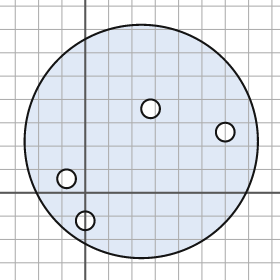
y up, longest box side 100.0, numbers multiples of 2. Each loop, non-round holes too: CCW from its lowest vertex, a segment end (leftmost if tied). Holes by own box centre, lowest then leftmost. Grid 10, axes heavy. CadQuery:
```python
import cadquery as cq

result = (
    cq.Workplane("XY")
    .moveTo(24.0, 22.0)
    .circle(50.0)
    .moveTo(0.0, -12.0)
    .circle(4.0)
    .moveTo(-8.0, 6.0)
    .circle(4.0)
    .moveTo(60.0, 26.0)
    .circle(4.0)
    .moveTo(28.0, 36.0)
    .circle(4.0)
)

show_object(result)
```